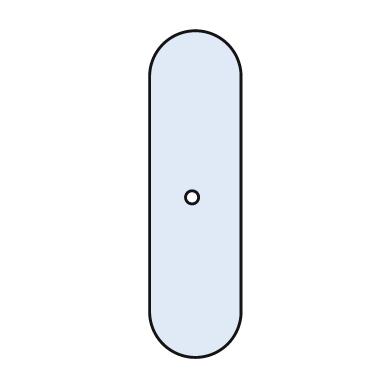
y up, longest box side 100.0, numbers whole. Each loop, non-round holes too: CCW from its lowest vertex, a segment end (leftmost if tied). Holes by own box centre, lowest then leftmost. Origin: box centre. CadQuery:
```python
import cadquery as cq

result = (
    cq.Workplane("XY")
    .moveTo(-14.0, -36.0)
    .threePointArc((0.0, -50.0), (14.0, -36.0))
    .lineTo(14.0, 36.0)
    .threePointArc((0.0, 50.0), (-14.0, 36.0))
    .close()
    .moveTo(-1.0, -1.0)
    .circle(2.0)
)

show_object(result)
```